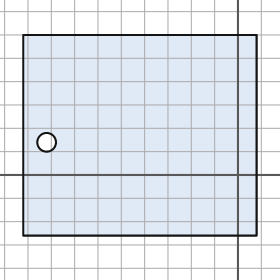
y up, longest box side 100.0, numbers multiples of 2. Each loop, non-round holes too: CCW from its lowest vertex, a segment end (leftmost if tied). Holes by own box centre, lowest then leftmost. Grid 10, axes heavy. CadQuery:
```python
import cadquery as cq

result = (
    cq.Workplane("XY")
    .moveTo(-92.0, -26.0)
    .lineTo(8.0, -26.0)
    .lineTo(8.0, 60.0)
    .lineTo(-92.0, 60.0)
    .close()
    .moveTo(-82.0, 14.0)
    .circle(4.0)
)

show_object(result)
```